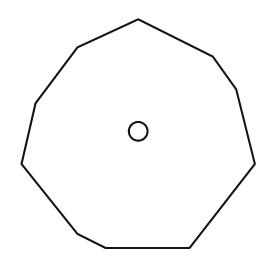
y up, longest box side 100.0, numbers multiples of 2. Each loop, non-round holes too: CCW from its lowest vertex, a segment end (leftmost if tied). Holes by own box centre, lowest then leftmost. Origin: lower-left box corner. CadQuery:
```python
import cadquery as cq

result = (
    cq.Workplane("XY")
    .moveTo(36.0, 0.0)
    .lineTo(72.0, 0.0)
    .lineTo(100.0, 36.0)
    .lineTo(92.0, 68.0)
    .lineTo(82.0, 82.0)
    .lineTo(50.0, 98.0)
    .lineTo(24.0, 86.0)
    .lineTo(6.0, 62.0)
    .lineTo(0.0, 36.0)
    .lineTo(24.0, 6.0)
    .close()
    .moveTo(50.0, 50.0)
    .circle(4.0)
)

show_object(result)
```